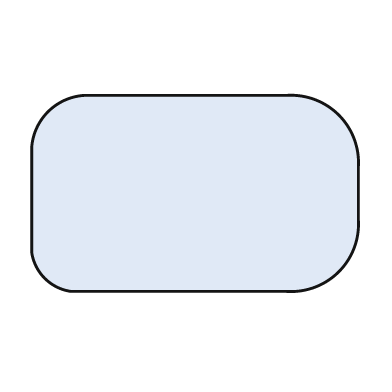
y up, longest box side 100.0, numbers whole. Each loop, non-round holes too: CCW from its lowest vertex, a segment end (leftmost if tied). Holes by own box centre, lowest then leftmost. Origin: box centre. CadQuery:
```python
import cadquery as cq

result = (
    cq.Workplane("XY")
    .moveTo(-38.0, -30.0)
    .lineTo(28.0, -30.0)
    .threePointArc((44.0, -24.0), (50.0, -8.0))
    .lineTo(50.0, 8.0)
    .threePointArc((44.0, 24.0), (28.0, 30.0))
    .lineTo(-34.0, 30.0)
    .threePointArc((-45.0, 25.0), (-50.0, 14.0))
    .lineTo(-50.0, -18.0)
    .threePointArc((-46.0, -26.0), (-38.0, -30.0))
    .close()
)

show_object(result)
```